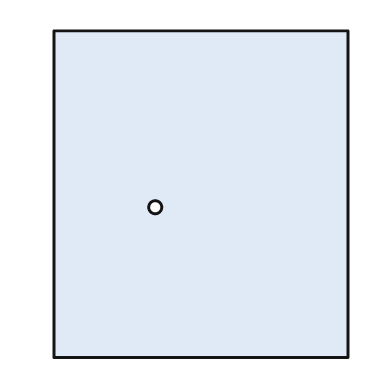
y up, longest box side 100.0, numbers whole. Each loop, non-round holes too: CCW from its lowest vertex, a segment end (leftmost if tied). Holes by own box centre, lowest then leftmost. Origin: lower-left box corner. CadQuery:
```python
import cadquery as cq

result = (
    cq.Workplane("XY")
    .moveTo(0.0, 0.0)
    .lineTo(90.0, 0.0)
    .lineTo(90.0, 100.0)
    .lineTo(0.0, 100.0)
    .close()
    .moveTo(31.0, 46.0)
    .circle(2.0)
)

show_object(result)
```